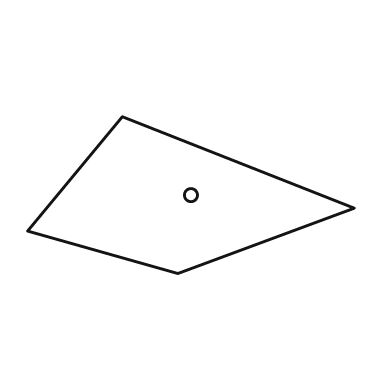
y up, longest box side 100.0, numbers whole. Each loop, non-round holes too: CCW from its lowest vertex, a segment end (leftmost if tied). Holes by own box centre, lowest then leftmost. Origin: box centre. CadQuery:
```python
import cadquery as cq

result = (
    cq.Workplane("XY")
    .moveTo(-4.0, -24.0)
    .lineTo(50.0, -4.0)
    .lineTo(-21.0, 24.0)
    .lineTo(-50.0, -11.0)
    .close()
    .moveTo(0.0, 0.0)
    .circle(2.0)
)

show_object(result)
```